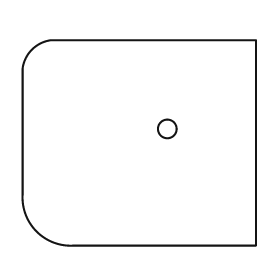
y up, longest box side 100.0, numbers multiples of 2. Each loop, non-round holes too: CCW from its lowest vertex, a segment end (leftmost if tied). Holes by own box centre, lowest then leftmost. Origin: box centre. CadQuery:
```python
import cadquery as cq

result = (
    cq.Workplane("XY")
    .moveTo(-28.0, -44.0)
    .lineTo(50.0, -44.0)
    .lineTo(50.0, 44.0)
    .lineTo(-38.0, 44.0)
    .threePointArc((-46.0, 40.0), (-50.0, 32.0))
    .lineTo(-50.0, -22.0)
    .threePointArc((-44.0, -38.0), (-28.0, -44.0))
    .close()
    .moveTo(12.0, 6.0)
    .circle(4.0)
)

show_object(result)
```